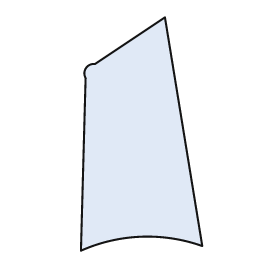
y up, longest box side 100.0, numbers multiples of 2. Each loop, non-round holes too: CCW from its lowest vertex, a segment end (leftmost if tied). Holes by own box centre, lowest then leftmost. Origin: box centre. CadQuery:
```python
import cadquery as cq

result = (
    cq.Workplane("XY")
    .moveTo(-26.0, -50.0)
    .threePointArc((0.0, -44.0), (26.0, -48.0))
    .lineTo(10.0, 50.0)
    .lineTo(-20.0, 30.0)
    .threePointArc((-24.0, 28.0), (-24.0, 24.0))
    .close()
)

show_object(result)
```